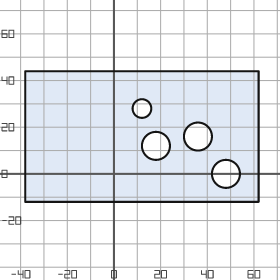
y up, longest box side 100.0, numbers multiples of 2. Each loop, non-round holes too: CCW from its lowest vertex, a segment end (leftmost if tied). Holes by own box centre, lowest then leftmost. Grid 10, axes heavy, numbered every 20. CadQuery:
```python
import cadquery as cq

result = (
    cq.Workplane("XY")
    .moveTo(-38.0, -12.0)
    .lineTo(62.0, -12.0)
    .lineTo(62.0, 44.0)
    .lineTo(-38.0, 44.0)
    .close()
    .moveTo(48.0, 0.0)
    .circle(6.0)
    .moveTo(18.0, 12.0)
    .circle(6.0)
    .moveTo(36.0, 16.0)
    .circle(6.0)
    .moveTo(12.0, 28.0)
    .circle(4.0)
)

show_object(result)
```